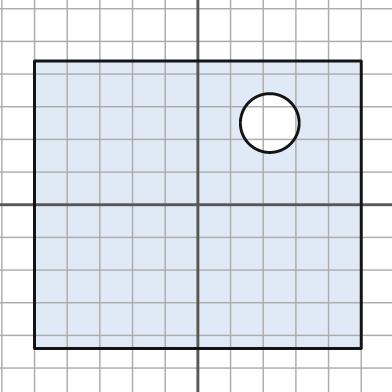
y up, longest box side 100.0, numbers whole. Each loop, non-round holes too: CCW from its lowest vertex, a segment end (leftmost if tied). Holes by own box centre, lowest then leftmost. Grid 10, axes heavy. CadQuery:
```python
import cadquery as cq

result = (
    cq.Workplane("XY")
    .moveTo(-50.0, -44.0)
    .lineTo(50.0, -44.0)
    .lineTo(50.0, 44.0)
    .lineTo(-50.0, 44.0)
    .close()
    .moveTo(22.0, 25.0)
    .circle(9.0)
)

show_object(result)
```